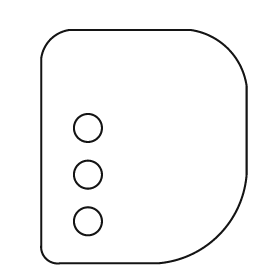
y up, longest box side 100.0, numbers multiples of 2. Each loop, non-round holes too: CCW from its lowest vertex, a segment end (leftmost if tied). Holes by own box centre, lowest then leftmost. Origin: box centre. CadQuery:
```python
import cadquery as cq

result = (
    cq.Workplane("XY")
    .moveTo(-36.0, -50.0)
    .lineTo(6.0, -50.0)
    .threePointArc((32.0, -38.0), (44.0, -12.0))
    .lineTo(44.0, 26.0)
    .threePointArc((36.0, 42.0), (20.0, 50.0))
    .lineTo(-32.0, 50.0)
    .threePointArc((-40.0, 46.0), (-44.0, 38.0))
    .lineTo(-44.0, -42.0)
    .threePointArc((-42.0, -48.0), (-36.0, -50.0))
    .close()
    .moveTo(-24.0, -32.0)
    .circle(6.0)
    .moveTo(-24.0, -12.0)
    .circle(6.0)
    .moveTo(-24.0, 8.0)
    .circle(6.0)
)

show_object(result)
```